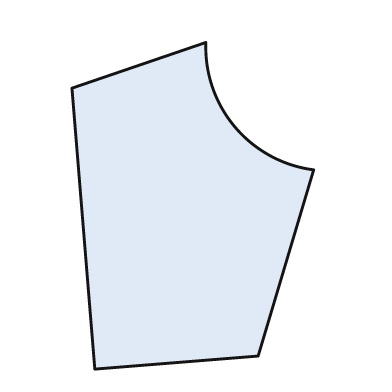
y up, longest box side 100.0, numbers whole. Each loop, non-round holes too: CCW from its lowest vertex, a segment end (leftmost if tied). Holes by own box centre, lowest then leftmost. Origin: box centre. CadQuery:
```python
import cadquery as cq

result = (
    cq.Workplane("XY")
    .moveTo(-30.0, -50.0)
    .lineTo(20.0, -46.0)
    .lineTo(37.0, 11.0)
    .threePointArc((13.0, 24.0), (4.0, 50.0))
    .lineTo(-37.0, 36.0)
    .close()
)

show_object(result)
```